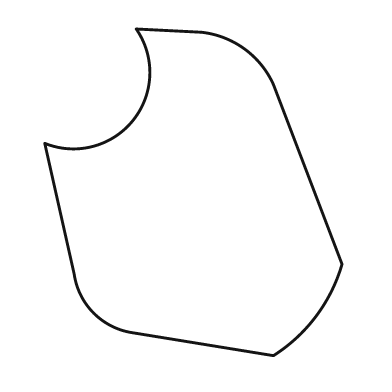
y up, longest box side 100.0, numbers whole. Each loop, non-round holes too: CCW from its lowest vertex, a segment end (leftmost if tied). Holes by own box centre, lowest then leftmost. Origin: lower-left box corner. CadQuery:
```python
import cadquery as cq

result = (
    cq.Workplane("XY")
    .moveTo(70.0, 0.0)
    .threePointArc((83.0, 12.0), (91.0, 28.0))
    .lineTo(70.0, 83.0)
    .threePointArc((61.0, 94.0), (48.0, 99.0))
    .lineTo(28.0, 100.0)
    .threePointArc((27.0, 72.0), (0.0, 65.0))
    .lineTo(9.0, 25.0)
    .threePointArc((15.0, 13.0), (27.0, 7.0))
    .close()
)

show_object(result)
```